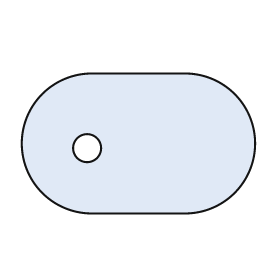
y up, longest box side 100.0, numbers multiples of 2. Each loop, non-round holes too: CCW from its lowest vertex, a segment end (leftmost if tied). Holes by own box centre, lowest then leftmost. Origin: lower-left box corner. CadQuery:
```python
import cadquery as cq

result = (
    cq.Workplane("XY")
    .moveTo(30.0, 0.0)
    .lineTo(70.0, 0.0)
    .threePointArc((100.0, 30.0), (70.0, 60.0))
    .lineTo(30.0, 60.0)
    .threePointArc((0.0, 30.0), (30.0, 0.0))
    .close()
    .moveTo(28.0, 28.0)
    .circle(6.0)
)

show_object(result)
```